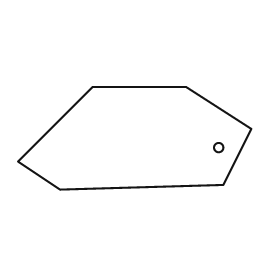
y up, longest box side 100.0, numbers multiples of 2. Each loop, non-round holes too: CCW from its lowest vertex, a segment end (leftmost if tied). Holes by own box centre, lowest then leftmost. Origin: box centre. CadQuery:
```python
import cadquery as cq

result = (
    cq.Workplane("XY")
    .moveTo(-32.0, -22.0)
    .lineTo(38.0, -20.0)
    .lineTo(50.0, 4.0)
    .lineTo(22.0, 22.0)
    .lineTo(-18.0, 22.0)
    .lineTo(-50.0, -10.0)
    .close()
    .moveTo(36.0, -4.0)
    .circle(2.0)
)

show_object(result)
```